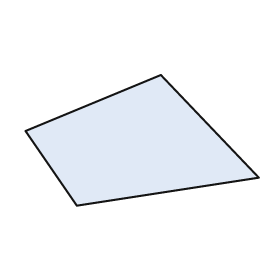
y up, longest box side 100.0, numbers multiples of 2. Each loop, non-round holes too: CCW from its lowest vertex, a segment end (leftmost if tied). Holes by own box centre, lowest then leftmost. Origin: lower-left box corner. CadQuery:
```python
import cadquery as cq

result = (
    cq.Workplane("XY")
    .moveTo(22.0, 0.0)
    .lineTo(100.0, 12.0)
    .lineTo(58.0, 56.0)
    .lineTo(0.0, 32.0)
    .close()
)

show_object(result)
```